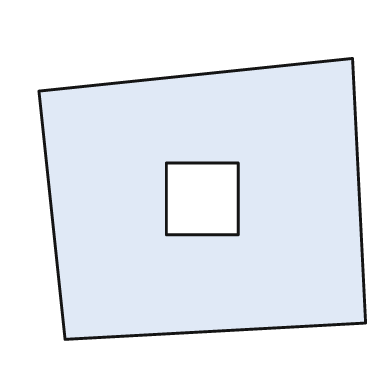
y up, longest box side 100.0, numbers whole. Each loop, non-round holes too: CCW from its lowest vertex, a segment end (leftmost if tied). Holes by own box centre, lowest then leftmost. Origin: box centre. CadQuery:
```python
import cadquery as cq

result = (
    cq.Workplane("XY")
    .moveTo(-42.0, -43.0)
    .lineTo(50.0, -38.0)
    .lineTo(46.0, 43.0)
    .lineTo(-50.0, 33.0)
    .close()
    .moveTo(-11.0, -11.0)
    .lineTo(11.0, -11.0)
    .lineTo(11.0, 11.0)
    .lineTo(-11.0, 11.0)
    .close()
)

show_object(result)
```